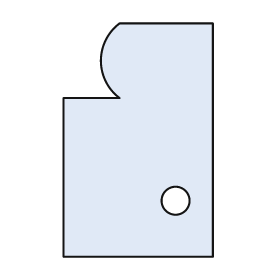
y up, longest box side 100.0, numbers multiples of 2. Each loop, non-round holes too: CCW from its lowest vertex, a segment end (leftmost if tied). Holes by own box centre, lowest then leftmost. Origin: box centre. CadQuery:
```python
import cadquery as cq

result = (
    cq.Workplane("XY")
    .moveTo(-32.0, -50.0)
    .lineTo(32.0, -50.0)
    .lineTo(32.0, 50.0)
    .lineTo(-8.0, 50.0)
    .threePointArc((-16.0, 34.0), (-8.0, 18.0))
    .lineTo(-32.0, 18.0)
    .close()
    .moveTo(16.0, -26.0)
    .circle(6.0)
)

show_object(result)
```